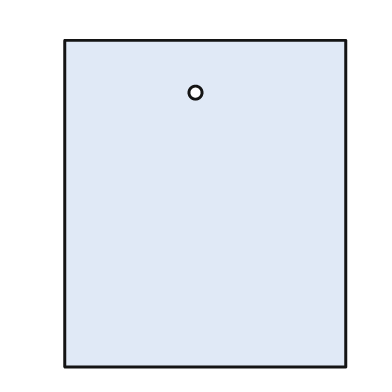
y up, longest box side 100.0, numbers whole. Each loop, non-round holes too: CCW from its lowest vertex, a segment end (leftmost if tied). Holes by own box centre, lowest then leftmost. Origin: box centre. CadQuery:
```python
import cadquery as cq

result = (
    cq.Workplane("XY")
    .moveTo(-43.0, -50.0)
    .lineTo(43.0, -50.0)
    .lineTo(43.0, 50.0)
    .lineTo(-43.0, 50.0)
    .close()
    .moveTo(-3.0, 34.0)
    .circle(2.0)
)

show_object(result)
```